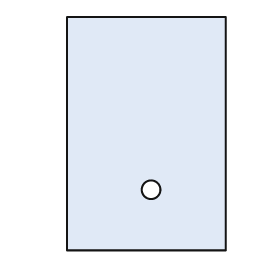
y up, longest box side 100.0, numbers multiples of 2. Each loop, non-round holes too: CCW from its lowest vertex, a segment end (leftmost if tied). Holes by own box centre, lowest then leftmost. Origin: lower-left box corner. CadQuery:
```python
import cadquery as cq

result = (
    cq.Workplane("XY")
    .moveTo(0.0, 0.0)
    .lineTo(68.0, 0.0)
    .lineTo(68.0, 100.0)
    .lineTo(0.0, 100.0)
    .close()
    .moveTo(36.0, 26.0)
    .circle(4.0)
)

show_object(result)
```